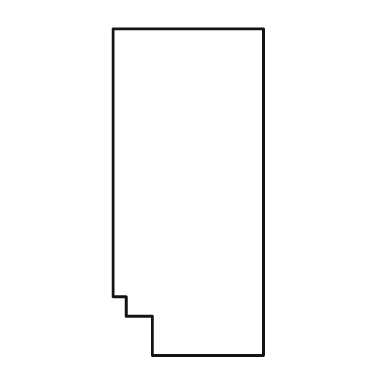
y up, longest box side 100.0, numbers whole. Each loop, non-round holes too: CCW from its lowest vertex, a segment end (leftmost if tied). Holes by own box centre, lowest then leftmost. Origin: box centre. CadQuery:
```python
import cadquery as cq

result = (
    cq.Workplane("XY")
    .moveTo(-11.0, -50.0)
    .lineTo(23.0, -50.0)
    .lineTo(23.0, 50.0)
    .lineTo(-23.0, 50.0)
    .lineTo(-23.0, -32.0)
    .lineTo(-19.0, -32.0)
    .lineTo(-19.0, -38.0)
    .lineTo(-11.0, -38.0)
    .close()
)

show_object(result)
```